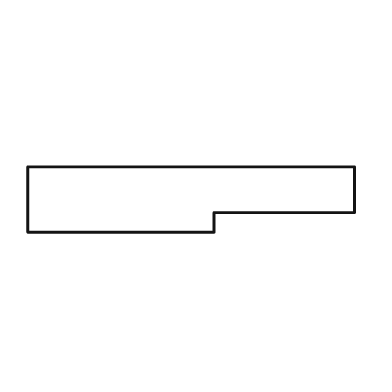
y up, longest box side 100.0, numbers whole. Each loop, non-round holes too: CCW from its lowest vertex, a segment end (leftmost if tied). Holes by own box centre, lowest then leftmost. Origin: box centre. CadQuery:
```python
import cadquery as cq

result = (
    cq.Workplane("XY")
    .moveTo(-50.0, -10.0)
    .lineTo(7.0, -10.0)
    .lineTo(7.0, -4.0)
    .lineTo(50.0, -4.0)
    .lineTo(50.0, 10.0)
    .lineTo(-50.0, 10.0)
    .close()
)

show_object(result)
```